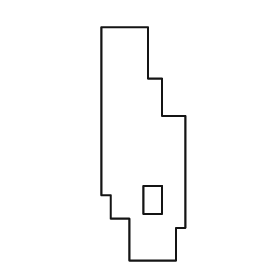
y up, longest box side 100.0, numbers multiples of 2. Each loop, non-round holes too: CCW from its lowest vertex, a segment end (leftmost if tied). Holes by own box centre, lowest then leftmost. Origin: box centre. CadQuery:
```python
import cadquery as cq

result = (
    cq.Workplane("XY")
    .moveTo(-6.0, -50.0)
    .lineTo(14.0, -50.0)
    .lineTo(14.0, -36.0)
    .lineTo(18.0, -36.0)
    .lineTo(18.0, 12.0)
    .lineTo(8.0, 12.0)
    .lineTo(8.0, 28.0)
    .lineTo(2.0, 28.0)
    .lineTo(2.0, 50.0)
    .lineTo(-18.0, 50.0)
    .lineTo(-18.0, -22.0)
    .lineTo(-14.0, -22.0)
    .lineTo(-14.0, -32.0)
    .lineTo(-6.0, -32.0)
    .close()
    .moveTo(0.0, -30.0)
    .lineTo(8.0, -30.0)
    .lineTo(8.0, -18.0)
    .lineTo(0.0, -18.0)
    .close()
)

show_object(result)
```